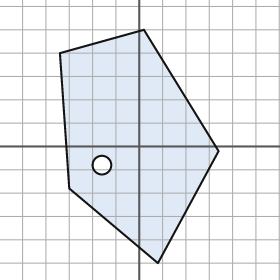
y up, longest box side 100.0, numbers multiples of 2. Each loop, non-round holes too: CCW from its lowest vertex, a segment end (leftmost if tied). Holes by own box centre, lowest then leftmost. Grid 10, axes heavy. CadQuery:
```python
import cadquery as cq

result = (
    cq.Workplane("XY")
    .moveTo(8.0, -50.0)
    .lineTo(34.0, -2.0)
    .lineTo(2.0, 50.0)
    .lineTo(-34.0, 40.0)
    .lineTo(-30.0, -18.0)
    .close()
    .moveTo(-16.0, -8.0)
    .circle(4.0)
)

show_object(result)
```